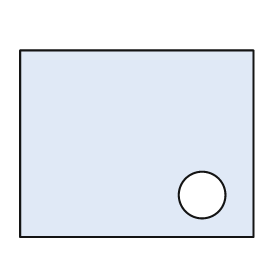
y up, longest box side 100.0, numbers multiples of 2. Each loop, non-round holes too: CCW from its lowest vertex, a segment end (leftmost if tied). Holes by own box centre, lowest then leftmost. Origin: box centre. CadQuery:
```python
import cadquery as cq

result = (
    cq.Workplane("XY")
    .moveTo(-50.0, -40.0)
    .lineTo(50.0, -40.0)
    .lineTo(50.0, 40.0)
    .lineTo(-50.0, 40.0)
    .close()
    .moveTo(28.0, -22.0)
    .circle(10.0)
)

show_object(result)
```